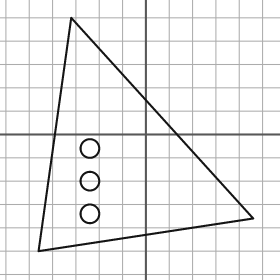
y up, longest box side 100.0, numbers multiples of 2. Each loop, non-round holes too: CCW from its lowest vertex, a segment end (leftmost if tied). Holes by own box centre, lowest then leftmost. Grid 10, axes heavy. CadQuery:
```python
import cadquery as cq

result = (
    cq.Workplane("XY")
    .moveTo(-46.0, -50.0)
    .lineTo(46.0, -36.0)
    .lineTo(-32.0, 50.0)
    .close()
    .moveTo(-24.0, -34.0)
    .circle(4.0)
    .moveTo(-24.0, -20.0)
    .circle(4.0)
    .moveTo(-24.0, -6.0)
    .circle(4.0)
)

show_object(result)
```